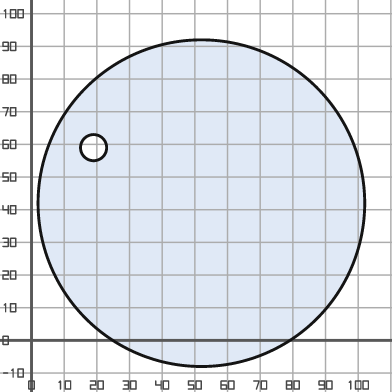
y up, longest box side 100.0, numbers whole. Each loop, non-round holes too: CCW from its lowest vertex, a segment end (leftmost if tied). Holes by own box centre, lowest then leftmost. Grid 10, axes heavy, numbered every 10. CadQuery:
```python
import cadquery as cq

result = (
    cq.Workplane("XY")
    .moveTo(52.0, 42.0)
    .circle(50.0)
    .moveTo(19.0, 59.0)
    .circle(4.0)
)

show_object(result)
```